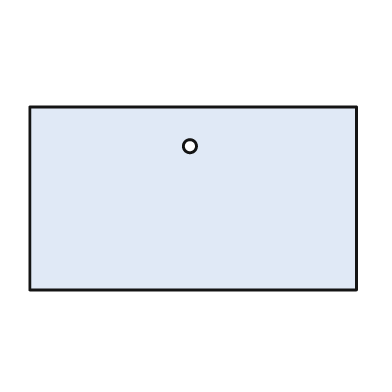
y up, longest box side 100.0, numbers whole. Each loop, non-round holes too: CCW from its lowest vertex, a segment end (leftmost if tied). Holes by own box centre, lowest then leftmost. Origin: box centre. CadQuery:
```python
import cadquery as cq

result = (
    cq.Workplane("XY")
    .moveTo(-50.0, -28.0)
    .lineTo(50.0, -28.0)
    .lineTo(50.0, 28.0)
    .lineTo(-50.0, 28.0)
    .close()
    .moveTo(-1.0, 16.0)
    .circle(2.0)
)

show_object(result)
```